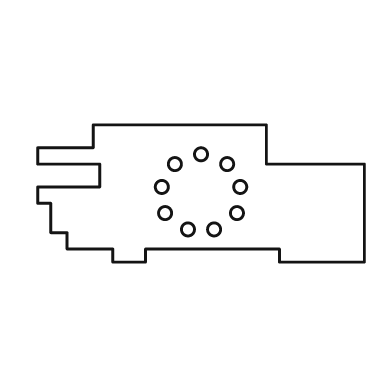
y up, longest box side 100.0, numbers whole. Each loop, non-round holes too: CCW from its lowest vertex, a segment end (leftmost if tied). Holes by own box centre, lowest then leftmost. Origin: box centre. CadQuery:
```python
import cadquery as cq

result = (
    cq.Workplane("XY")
    .moveTo(-27.0, -21.0)
    .lineTo(-17.0, -21.0)
    .lineTo(-17.0, -17.0)
    .lineTo(24.0, -17.0)
    .lineTo(24.0, -21.0)
    .lineTo(50.0, -21.0)
    .lineTo(50.0, 9.0)
    .lineTo(20.0, 9.0)
    .lineTo(20.0, 21.0)
    .lineTo(-33.0, 21.0)
    .lineTo(-33.0, 14.0)
    .lineTo(-50.0, 14.0)
    .lineTo(-50.0, 9.0)
    .lineTo(-31.0, 9.0)
    .lineTo(-31.0, 2.0)
    .lineTo(-50.0, 2.0)
    .lineTo(-50.0, -3.0)
    .lineTo(-46.0, -3.0)
    .lineTo(-46.0, -12.0)
    .lineTo(-41.0, -12.0)
    .lineTo(-41.0, -17.0)
    .lineTo(-27.0, -17.0)
    .close()
    .moveTo(-4.0, -11.0)
    .circle(2.0)
    .moveTo(4.0, -11.0)
    .circle(2.0)
    .moveTo(-11.0, -6.0)
    .circle(2.0)
    .moveTo(11.0, -6.0)
    .circle(2.0)
    .moveTo(-12.0, 2.0)
    .circle(2.0)
    .moveTo(12.0, 2.0)
    .circle(2.0)
    .moveTo(-8.0, 9.0)
    .circle(2.0)
    .moveTo(8.0, 9.0)
    .circle(2.0)
    .moveTo(0.0, 12.0)
    .circle(2.0)
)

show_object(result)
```